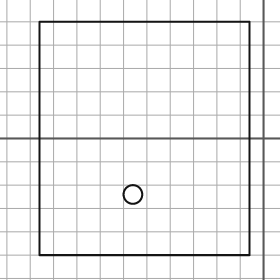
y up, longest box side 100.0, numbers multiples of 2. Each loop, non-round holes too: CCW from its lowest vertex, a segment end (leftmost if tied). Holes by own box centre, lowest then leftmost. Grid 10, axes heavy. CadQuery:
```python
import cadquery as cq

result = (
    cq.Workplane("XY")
    .moveTo(-96.0, -50.0)
    .lineTo(-6.0, -50.0)
    .lineTo(-6.0, 50.0)
    .lineTo(-96.0, 50.0)
    .close()
    .moveTo(-56.0, -24.0)
    .circle(4.0)
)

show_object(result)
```